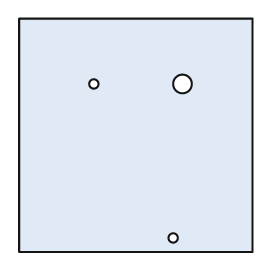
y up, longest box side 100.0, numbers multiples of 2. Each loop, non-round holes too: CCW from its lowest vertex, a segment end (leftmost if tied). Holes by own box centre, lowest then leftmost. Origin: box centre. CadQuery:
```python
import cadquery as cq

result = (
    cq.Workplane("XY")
    .moveTo(-50.0, -50.0)
    .lineTo(50.0, -50.0)
    .lineTo(50.0, 50.0)
    .lineTo(-50.0, 50.0)
    .close()
    .moveTo(16.0, -44.0)
    .circle(2.0)
    .moveTo(-18.0, 22.0)
    .circle(2.0)
    .moveTo(20.0, 22.0)
    .circle(4.0)
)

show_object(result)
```